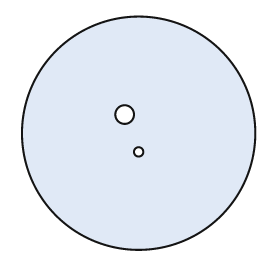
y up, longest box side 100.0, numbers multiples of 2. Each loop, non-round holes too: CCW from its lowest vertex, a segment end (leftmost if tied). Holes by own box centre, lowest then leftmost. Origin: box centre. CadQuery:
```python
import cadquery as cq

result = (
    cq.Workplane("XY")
    .moveTo(0.0, 0.0)
    .circle(50.0)
    .moveTo(0.0, -8.0)
    .circle(2.0)
    .moveTo(-6.0, 8.0)
    .circle(4.0)
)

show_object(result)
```